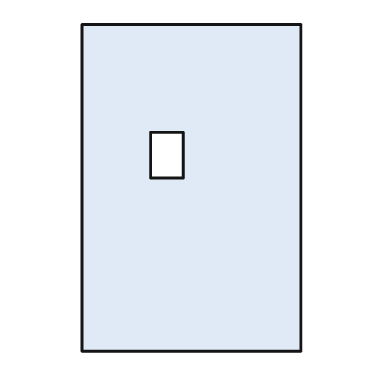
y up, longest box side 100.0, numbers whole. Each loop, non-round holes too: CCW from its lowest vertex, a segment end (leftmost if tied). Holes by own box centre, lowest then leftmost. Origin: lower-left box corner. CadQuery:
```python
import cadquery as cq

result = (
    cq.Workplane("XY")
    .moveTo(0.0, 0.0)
    .lineTo(67.0, 0.0)
    .lineTo(67.0, 100.0)
    .lineTo(0.0, 100.0)
    .close()
    .moveTo(21.0, 53.0)
    .lineTo(31.0, 53.0)
    .lineTo(31.0, 67.0)
    .lineTo(21.0, 67.0)
    .close()
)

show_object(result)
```